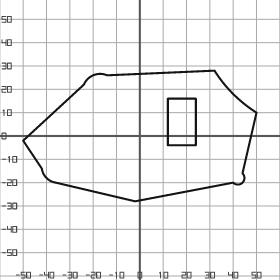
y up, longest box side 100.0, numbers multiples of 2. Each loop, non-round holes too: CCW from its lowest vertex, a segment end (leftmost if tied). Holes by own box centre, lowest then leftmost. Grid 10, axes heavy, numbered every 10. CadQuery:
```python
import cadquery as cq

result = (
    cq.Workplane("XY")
    .moveTo(-2.0, -28.0)
    .lineTo(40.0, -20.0)
    .threePointArc((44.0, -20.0), (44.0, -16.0))
    .lineTo(50.0, 10.0)
    .threePointArc((40.0, 18.0), (32.0, 28.0))
    .lineTo(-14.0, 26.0)
    .threePointArc((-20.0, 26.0), (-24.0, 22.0))
    .lineTo(-50.0, -2.0)
    .lineTo(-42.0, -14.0)
    .threePointArc((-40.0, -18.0), (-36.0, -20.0))
    .close()
    .moveTo(12.0, -4.0)
    .lineTo(24.0, -4.0)
    .lineTo(24.0, 16.0)
    .lineTo(12.0, 16.0)
    .close()
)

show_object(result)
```